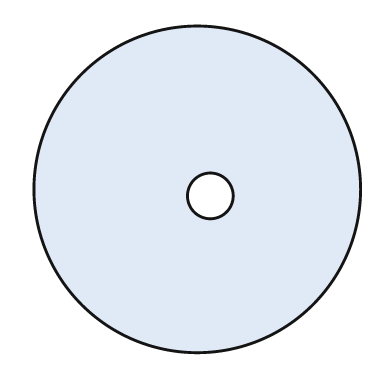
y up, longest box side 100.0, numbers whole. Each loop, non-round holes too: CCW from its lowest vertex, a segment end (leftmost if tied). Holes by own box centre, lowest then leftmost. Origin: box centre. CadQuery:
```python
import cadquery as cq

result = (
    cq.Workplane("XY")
    .moveTo(0.0, 0.0)
    .circle(50.0)
    .moveTo(4.0, -2.0)
    .circle(7.0)
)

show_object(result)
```